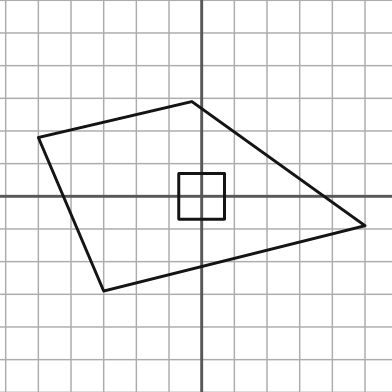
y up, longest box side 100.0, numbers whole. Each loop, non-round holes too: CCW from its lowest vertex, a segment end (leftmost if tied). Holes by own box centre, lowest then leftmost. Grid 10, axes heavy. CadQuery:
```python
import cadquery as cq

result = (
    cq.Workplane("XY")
    .moveTo(-30.0, -29.0)
    .lineTo(50.0, -9.0)
    .lineTo(-3.0, 29.0)
    .lineTo(-50.0, 18.0)
    .close()
    .moveTo(-7.0, -7.0)
    .lineTo(7.0, -7.0)
    .lineTo(7.0, 7.0)
    .lineTo(-7.0, 7.0)
    .close()
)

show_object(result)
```